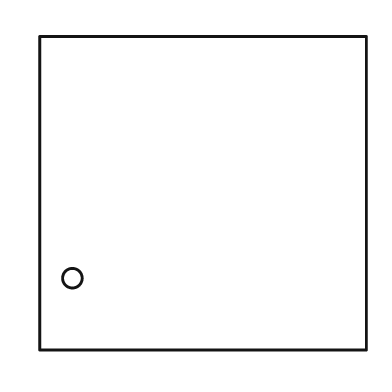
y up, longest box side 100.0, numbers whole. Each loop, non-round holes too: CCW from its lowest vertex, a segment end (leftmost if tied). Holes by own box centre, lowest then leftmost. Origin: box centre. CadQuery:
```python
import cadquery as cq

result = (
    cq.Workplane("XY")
    .moveTo(-50.0, -48.0)
    .lineTo(50.0, -48.0)
    .lineTo(50.0, 48.0)
    .lineTo(-50.0, 48.0)
    .close()
    .moveTo(-40.0, -26.0)
    .circle(3.0)
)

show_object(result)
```